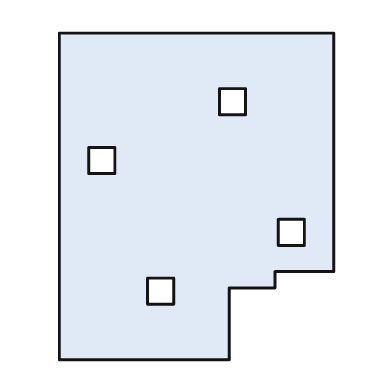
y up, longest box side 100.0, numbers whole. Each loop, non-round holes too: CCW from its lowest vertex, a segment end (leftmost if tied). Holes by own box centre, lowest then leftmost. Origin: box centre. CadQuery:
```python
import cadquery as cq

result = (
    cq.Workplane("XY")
    .moveTo(-42.0, -50.0)
    .lineTo(10.0, -50.0)
    .lineTo(10.0, -28.0)
    .lineTo(24.0, -28.0)
    .lineTo(24.0, -23.0)
    .lineTo(42.0, -23.0)
    .lineTo(42.0, 50.0)
    .lineTo(-42.0, 50.0)
    .close()
    .moveTo(-15.0, -33.0)
    .lineTo(-7.0, -33.0)
    .lineTo(-7.0, -25.0)
    .lineTo(-15.0, -25.0)
    .close()
    .moveTo(25.0, -15.0)
    .lineTo(33.0, -15.0)
    .lineTo(33.0, -7.0)
    .lineTo(25.0, -7.0)
    .close()
    .moveTo(-33.0, 7.0)
    .lineTo(-25.0, 7.0)
    .lineTo(-25.0, 15.0)
    .lineTo(-33.0, 15.0)
    .close()
    .moveTo(7.0, 25.0)
    .lineTo(15.0, 25.0)
    .lineTo(15.0, 33.0)
    .lineTo(7.0, 33.0)
    .close()
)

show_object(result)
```